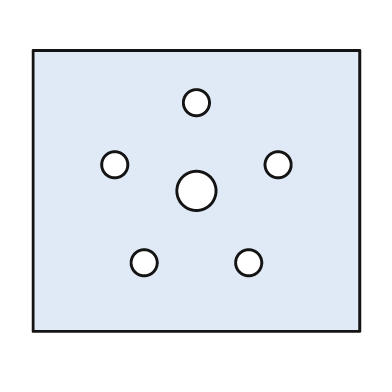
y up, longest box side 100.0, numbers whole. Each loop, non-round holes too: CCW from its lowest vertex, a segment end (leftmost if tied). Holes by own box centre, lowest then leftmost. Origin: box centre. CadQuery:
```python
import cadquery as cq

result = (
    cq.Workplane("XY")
    .moveTo(-50.0, -43.0)
    .lineTo(50.0, -43.0)
    .lineTo(50.0, 43.0)
    .lineTo(-50.0, 43.0)
    .close()
    .moveTo(-16.0, -22.0)
    .circle(4.0)
    .moveTo(16.0, -22.0)
    .circle(4.0)
    .moveTo(0.0, 0.0)
    .circle(6.0)
    .moveTo(-25.0, 8.0)
    .circle(4.0)
    .moveTo(25.0, 8.0)
    .circle(4.0)
    .moveTo(0.0, 27.0)
    .circle(4.0)
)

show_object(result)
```